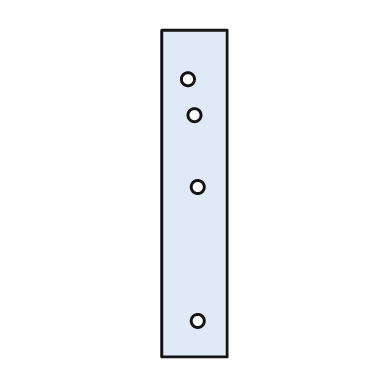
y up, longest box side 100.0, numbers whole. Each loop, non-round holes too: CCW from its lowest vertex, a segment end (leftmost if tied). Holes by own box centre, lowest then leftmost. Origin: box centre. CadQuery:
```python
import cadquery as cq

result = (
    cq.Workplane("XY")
    .moveTo(-10.0, -50.0)
    .lineTo(10.0, -50.0)
    .lineTo(10.0, 50.0)
    .lineTo(-10.0, 50.0)
    .close()
    .moveTo(1.0, -39.0)
    .circle(2.0)
    .moveTo(1.0, 2.0)
    .circle(2.0)
    .moveTo(0.0, 24.0)
    .circle(2.0)
    .moveTo(-2.0, 35.0)
    .circle(2.0)
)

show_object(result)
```